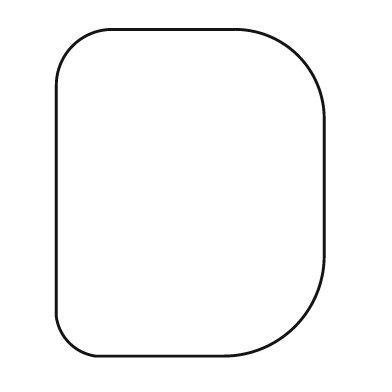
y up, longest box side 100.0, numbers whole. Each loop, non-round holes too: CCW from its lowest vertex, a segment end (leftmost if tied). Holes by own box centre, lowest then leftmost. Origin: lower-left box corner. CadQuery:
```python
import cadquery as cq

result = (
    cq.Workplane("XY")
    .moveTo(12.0, 0.0)
    .lineTo(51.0, 0.0)
    .threePointArc((73.0, 9.0), (82.0, 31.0))
    .lineTo(82.0, 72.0)
    .threePointArc((74.0, 92.0), (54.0, 100.0))
    .lineTo(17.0, 100.0)
    .threePointArc((5.0, 95.0), (0.0, 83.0))
    .lineTo(0.0, 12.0)
    .threePointArc((4.0, 4.0), (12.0, 0.0))
    .close()
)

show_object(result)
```